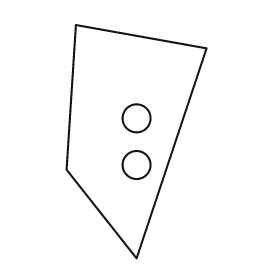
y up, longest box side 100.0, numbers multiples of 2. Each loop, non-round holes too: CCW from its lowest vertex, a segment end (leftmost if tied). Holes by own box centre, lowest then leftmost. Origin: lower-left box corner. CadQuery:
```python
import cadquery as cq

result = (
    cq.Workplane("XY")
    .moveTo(30.0, 0.0)
    .lineTo(60.0, 90.0)
    .lineTo(4.0, 100.0)
    .lineTo(0.0, 38.0)
    .close()
    .moveTo(30.0, 40.0)
    .circle(6.0)
    .moveTo(30.0, 60.0)
    .circle(6.0)
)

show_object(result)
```